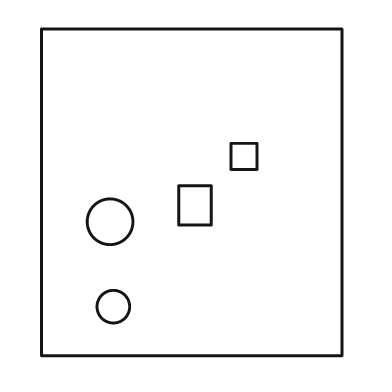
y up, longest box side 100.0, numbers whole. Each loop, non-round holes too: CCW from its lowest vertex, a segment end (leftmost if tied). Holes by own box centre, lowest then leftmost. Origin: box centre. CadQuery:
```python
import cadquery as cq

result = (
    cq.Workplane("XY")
    .moveTo(-46.0, -50.0)
    .lineTo(46.0, -50.0)
    .lineTo(46.0, 50.0)
    .lineTo(-46.0, 50.0)
    .close()
    .moveTo(-24.0, -35.0)
    .circle(5.0)
    .moveTo(-25.0, -9.0)
    .circle(7.0)
    .moveTo(-4.0, -10.0)
    .lineTo(6.0, -10.0)
    .lineTo(6.0, 2.0)
    .lineTo(-4.0, 2.0)
    .close()
    .moveTo(12.0, 7.0)
    .lineTo(20.0, 7.0)
    .lineTo(20.0, 15.0)
    .lineTo(12.0, 15.0)
    .close()
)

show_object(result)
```